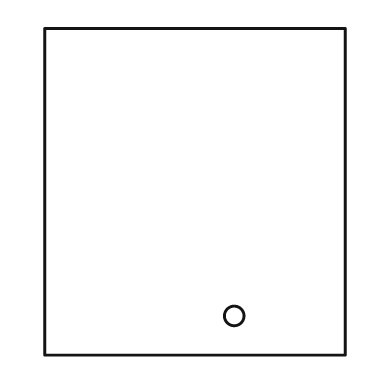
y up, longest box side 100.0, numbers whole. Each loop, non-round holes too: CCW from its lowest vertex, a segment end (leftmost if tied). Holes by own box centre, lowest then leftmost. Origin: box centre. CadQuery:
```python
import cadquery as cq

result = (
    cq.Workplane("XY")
    .moveTo(-46.0, -50.0)
    .lineTo(46.0, -50.0)
    .lineTo(46.0, 50.0)
    .lineTo(-46.0, 50.0)
    .close()
    .moveTo(12.0, -38.0)
    .circle(3.0)
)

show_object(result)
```